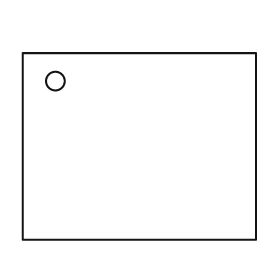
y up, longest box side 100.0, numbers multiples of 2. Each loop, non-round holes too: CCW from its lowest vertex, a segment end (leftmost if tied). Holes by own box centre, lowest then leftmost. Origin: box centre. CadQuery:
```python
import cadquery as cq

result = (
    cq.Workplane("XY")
    .moveTo(-50.0, -40.0)
    .lineTo(50.0, -40.0)
    .lineTo(50.0, 40.0)
    .lineTo(-50.0, 40.0)
    .close()
    .moveTo(-36.0, 28.0)
    .circle(4.0)
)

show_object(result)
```